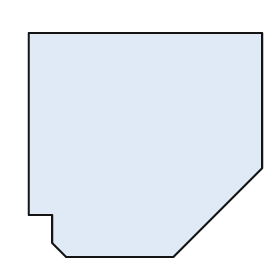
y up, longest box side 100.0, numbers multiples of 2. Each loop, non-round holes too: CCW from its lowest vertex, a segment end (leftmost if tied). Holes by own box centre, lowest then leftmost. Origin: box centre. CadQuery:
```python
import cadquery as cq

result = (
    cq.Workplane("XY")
    .moveTo(-34.0, -48.0)
    .lineTo(12.0, -48.0)
    .lineTo(50.0, -10.0)
    .lineTo(50.0, 48.0)
    .lineTo(-50.0, 48.0)
    .lineTo(-50.0, -30.0)
    .lineTo(-40.0, -30.0)
    .lineTo(-40.0, -42.0)
    .close()
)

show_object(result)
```